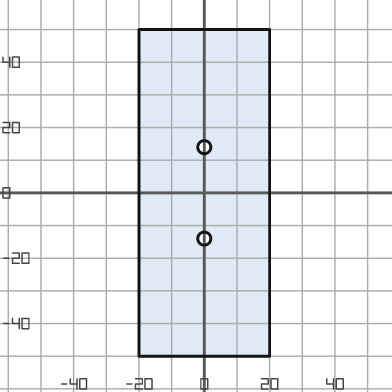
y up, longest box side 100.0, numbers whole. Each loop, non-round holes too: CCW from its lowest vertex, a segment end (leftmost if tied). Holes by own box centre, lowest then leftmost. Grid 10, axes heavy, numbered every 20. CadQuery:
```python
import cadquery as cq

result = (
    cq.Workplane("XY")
    .moveTo(-20.0, -50.0)
    .lineTo(20.0, -50.0)
    .lineTo(20.0, 50.0)
    .lineTo(-20.0, 50.0)
    .close()
    .moveTo(0.0, -14.0)
    .circle(2.0)
    .moveTo(0.0, 14.0)
    .circle(2.0)
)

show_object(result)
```